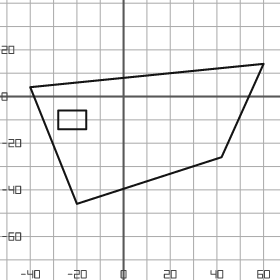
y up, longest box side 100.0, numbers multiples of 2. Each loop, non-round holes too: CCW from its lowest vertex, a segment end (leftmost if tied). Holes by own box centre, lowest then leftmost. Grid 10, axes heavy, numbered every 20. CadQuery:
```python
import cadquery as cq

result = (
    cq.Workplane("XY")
    .moveTo(-20.0, -46.0)
    .lineTo(42.0, -26.0)
    .lineTo(60.0, 14.0)
    .lineTo(-40.0, 4.0)
    .close()
    .moveTo(-28.0, -14.0)
    .lineTo(-16.0, -14.0)
    .lineTo(-16.0, -6.0)
    .lineTo(-28.0, -6.0)
    .close()
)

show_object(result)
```